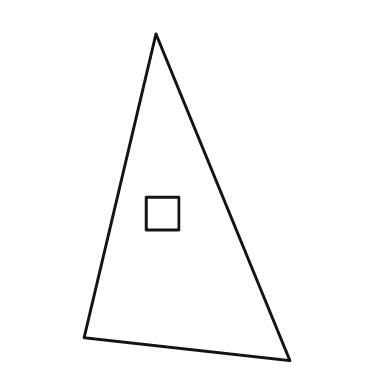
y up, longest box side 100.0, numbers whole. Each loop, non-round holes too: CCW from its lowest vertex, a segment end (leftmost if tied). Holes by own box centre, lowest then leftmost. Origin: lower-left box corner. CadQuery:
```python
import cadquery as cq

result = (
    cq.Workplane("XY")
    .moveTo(63.0, 0.0)
    .lineTo(22.0, 100.0)
    .lineTo(0.0, 7.0)
    .close()
    .moveTo(19.0, 40.0)
    .lineTo(29.0, 40.0)
    .lineTo(29.0, 50.0)
    .lineTo(19.0, 50.0)
    .close()
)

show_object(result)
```